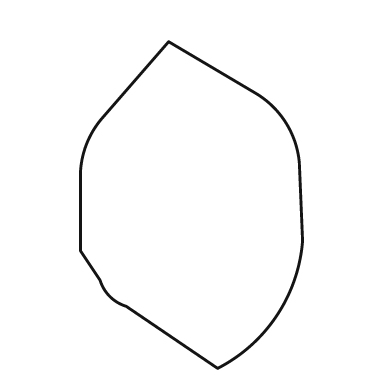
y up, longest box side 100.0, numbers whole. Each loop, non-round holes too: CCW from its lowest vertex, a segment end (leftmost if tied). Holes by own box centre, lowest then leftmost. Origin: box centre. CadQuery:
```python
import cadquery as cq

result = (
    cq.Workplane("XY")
    .moveTo(8.0, -50.0)
    .threePointArc((26.0, -34.0), (34.0, -11.0))
    .lineTo(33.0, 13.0)
    .threePointArc((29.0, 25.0), (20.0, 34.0))
    .lineTo(-7.0, 50.0)
    .lineTo(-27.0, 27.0)
    .threePointArc((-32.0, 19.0), (-34.0, 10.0))
    .lineTo(-34.0, -14.0)
    .lineTo(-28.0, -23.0)
    .threePointArc((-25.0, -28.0), (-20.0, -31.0))
    .close()
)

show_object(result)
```